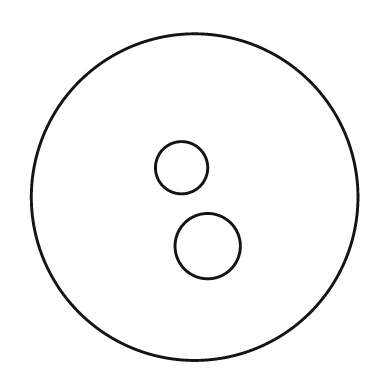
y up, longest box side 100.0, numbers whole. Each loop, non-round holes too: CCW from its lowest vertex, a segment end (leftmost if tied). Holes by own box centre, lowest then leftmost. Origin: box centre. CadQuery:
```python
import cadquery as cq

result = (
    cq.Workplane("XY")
    .moveTo(0.0, 0.0)
    .circle(50.0)
    .moveTo(4.0, -15.0)
    .circle(10.0)
    .moveTo(-4.0, 9.0)
    .circle(8.0)
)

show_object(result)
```